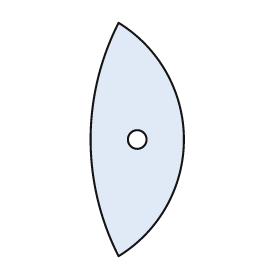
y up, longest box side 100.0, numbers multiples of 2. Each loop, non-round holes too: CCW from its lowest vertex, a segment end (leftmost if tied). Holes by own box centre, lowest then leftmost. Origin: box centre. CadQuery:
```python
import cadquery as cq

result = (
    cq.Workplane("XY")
    .moveTo(-8.0, -50.0)
    .threePointArc((20.0, 0.0), (-8.0, 50.0))
    .threePointArc((-20.0, 0.0), (-8.0, -50.0))
    .close()
    .moveTo(0.0, 0.0)
    .circle(4.0)
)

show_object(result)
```